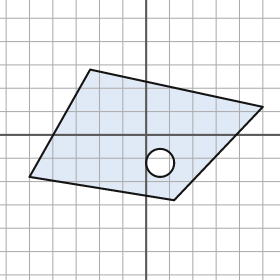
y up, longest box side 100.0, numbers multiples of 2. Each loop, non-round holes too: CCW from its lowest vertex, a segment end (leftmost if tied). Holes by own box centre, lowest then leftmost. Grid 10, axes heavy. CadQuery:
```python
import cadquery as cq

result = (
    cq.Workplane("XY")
    .moveTo(12.0, -28.0)
    .lineTo(50.0, 12.0)
    .lineTo(-24.0, 28.0)
    .lineTo(-50.0, -18.0)
    .close()
    .moveTo(6.0, -12.0)
    .circle(6.0)
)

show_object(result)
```